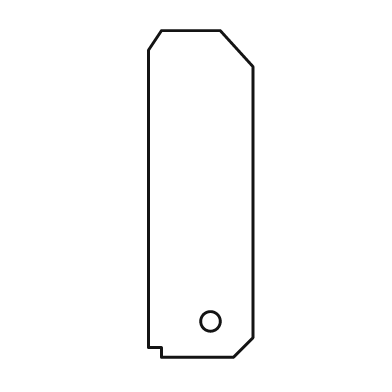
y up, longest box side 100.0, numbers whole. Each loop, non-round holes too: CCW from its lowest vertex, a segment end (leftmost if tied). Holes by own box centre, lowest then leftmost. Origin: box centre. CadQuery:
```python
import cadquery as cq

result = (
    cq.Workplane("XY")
    .moveTo(-12.0, -50.0)
    .lineTo(10.0, -50.0)
    .lineTo(16.0, -44.0)
    .lineTo(16.0, 39.0)
    .lineTo(6.0, 50.0)
    .lineTo(-12.0, 50.0)
    .lineTo(-16.0, 44.0)
    .lineTo(-16.0, -47.0)
    .lineTo(-12.0, -47.0)
    .close()
    .moveTo(3.0, -39.0)
    .circle(3.0)
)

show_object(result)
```